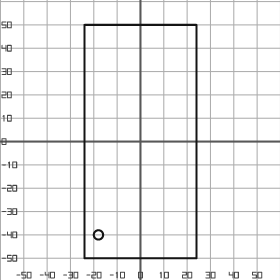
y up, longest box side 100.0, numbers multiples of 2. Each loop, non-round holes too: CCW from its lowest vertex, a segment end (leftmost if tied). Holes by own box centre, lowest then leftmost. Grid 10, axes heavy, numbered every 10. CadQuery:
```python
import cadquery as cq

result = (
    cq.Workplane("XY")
    .moveTo(-24.0, -50.0)
    .lineTo(24.0, -50.0)
    .lineTo(24.0, 50.0)
    .lineTo(-24.0, 50.0)
    .close()
    .moveTo(-18.0, -40.0)
    .circle(2.0)
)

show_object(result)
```